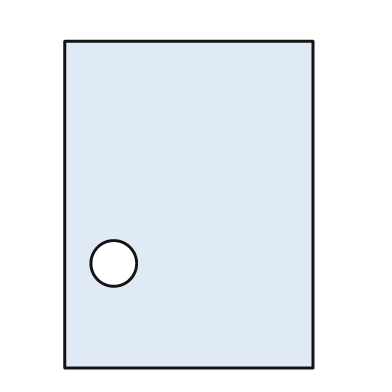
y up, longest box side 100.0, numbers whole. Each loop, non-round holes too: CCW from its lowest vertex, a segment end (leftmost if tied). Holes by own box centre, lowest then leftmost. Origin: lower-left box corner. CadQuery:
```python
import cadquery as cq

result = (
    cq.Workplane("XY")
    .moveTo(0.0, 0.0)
    .lineTo(76.0, 0.0)
    .lineTo(76.0, 100.0)
    .lineTo(0.0, 100.0)
    .close()
    .moveTo(15.0, 32.0)
    .circle(7.0)
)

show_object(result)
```